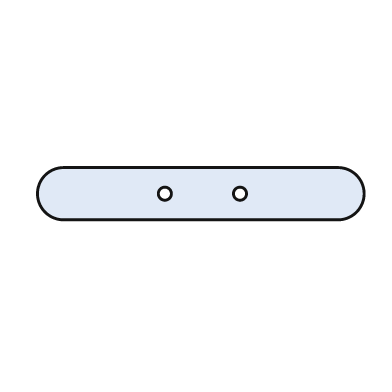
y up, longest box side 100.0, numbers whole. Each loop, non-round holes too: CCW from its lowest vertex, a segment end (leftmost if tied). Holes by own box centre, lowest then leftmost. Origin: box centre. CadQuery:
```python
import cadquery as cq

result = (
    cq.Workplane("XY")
    .moveTo(-42.0, -8.0)
    .lineTo(42.0, -8.0)
    .threePointArc((50.0, 0.0), (42.0, 8.0))
    .lineTo(-42.0, 8.0)
    .threePointArc((-50.0, 0.0), (-42.0, -8.0))
    .close()
    .moveTo(-11.0, 0.0)
    .circle(2.0)
    .moveTo(12.0, 0.0)
    .circle(2.0)
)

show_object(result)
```